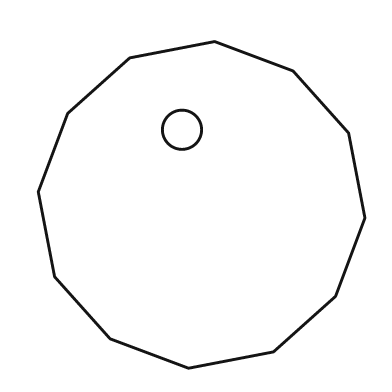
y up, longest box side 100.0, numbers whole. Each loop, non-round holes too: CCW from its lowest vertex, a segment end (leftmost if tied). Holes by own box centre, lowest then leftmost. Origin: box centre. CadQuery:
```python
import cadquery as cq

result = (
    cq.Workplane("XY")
    .moveTo(-4.0, -50.0)
    .lineTo(22.0, -45.0)
    .lineTo(41.0, -28.0)
    .lineTo(50.0, -4.0)
    .lineTo(45.0, 22.0)
    .lineTo(28.0, 41.0)
    .lineTo(4.0, 50.0)
    .lineTo(-22.0, 45.0)
    .lineTo(-41.0, 28.0)
    .lineTo(-50.0, 4.0)
    .lineTo(-45.0, -22.0)
    .lineTo(-28.0, -41.0)
    .close()
    .moveTo(-6.0, 23.0)
    .circle(6.0)
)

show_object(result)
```